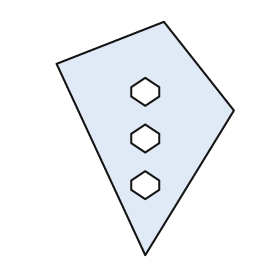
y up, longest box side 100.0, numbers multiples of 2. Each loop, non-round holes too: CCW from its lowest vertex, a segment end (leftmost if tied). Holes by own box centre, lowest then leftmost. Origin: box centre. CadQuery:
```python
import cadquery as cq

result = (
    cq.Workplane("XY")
    .moveTo(0.0, -50.0)
    .lineTo(38.0, 12.0)
    .lineTo(8.0, 50.0)
    .lineTo(-38.0, 32.0)
    .close()
    .moveTo(0.0, -26.0)
    .lineTo(6.0, -22.0)
    .lineTo(6.0, -18.0)
    .lineTo(0.0, -14.0)
    .lineTo(-6.0, -18.0)
    .lineTo(-6.0, -22.0)
    .close()
    .moveTo(0.0, -6.0)
    .lineTo(6.0, -2.0)
    .lineTo(6.0, 2.0)
    .lineTo(0.0, 6.0)
    .lineTo(-6.0, 2.0)
    .lineTo(-6.0, -2.0)
    .close()
    .moveTo(0.0, 14.0)
    .lineTo(6.0, 18.0)
    .lineTo(6.0, 22.0)
    .lineTo(0.0, 26.0)
    .lineTo(-6.0, 22.0)
    .lineTo(-6.0, 18.0)
    .close()
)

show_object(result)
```